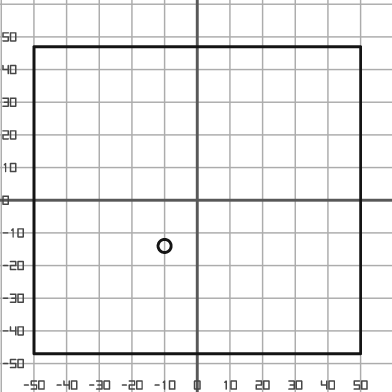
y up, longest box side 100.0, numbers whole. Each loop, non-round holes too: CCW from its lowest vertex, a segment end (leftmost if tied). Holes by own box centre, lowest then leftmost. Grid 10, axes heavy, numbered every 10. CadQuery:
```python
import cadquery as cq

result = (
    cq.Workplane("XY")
    .moveTo(-50.0, -47.0)
    .lineTo(50.0, -47.0)
    .lineTo(50.0, 47.0)
    .lineTo(-50.0, 47.0)
    .close()
    .moveTo(-10.0, -14.0)
    .circle(2.0)
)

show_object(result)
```